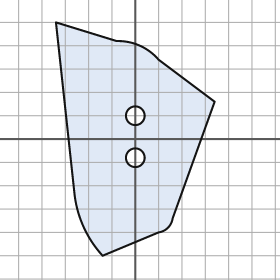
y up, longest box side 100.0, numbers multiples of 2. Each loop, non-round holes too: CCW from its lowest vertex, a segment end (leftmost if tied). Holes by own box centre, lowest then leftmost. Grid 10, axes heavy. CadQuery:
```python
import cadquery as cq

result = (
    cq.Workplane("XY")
    .moveTo(-14.0, -50.0)
    .lineTo(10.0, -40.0)
    .threePointArc((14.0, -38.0), (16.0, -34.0))
    .lineTo(34.0, 16.0)
    .lineTo(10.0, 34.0)
    .threePointArc((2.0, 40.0), (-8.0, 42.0))
    .lineTo(-34.0, 50.0)
    .lineTo(-26.0, -24.0)
    .threePointArc((-22.0, -38.0), (-14.0, -50.0))
    .close()
    .moveTo(0.0, -8.0)
    .circle(4.0)
    .moveTo(0.0, 10.0)
    .circle(4.0)
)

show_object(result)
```